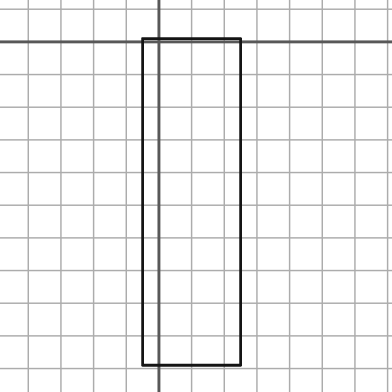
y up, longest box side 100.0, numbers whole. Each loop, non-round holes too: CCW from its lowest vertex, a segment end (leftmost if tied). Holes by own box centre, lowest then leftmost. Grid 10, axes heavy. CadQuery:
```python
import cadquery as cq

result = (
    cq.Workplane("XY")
    .moveTo(-5.0, -99.0)
    .lineTo(25.0, -99.0)
    .lineTo(25.0, 1.0)
    .lineTo(-5.0, 1.0)
    .close()
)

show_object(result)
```